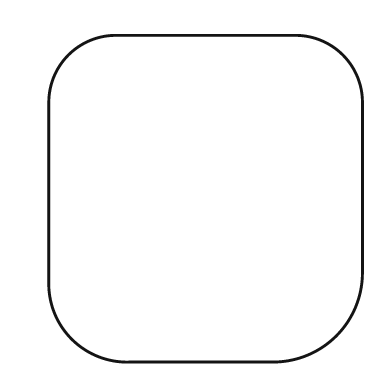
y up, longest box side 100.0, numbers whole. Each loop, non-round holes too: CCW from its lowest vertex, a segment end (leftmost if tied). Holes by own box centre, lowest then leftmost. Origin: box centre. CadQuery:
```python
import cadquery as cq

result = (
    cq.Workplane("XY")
    .moveTo(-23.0, -50.0)
    .lineTo(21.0, -50.0)
    .threePointArc((40.0, -42.0), (48.0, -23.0))
    .lineTo(48.0, 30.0)
    .threePointArc((42.0, 44.0), (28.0, 50.0))
    .lineTo(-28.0, 50.0)
    .threePointArc((-42.0, 44.0), (-48.0, 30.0))
    .lineTo(-48.0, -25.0)
    .threePointArc((-41.0, -43.0), (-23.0, -50.0))
    .close()
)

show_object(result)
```